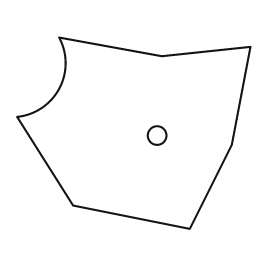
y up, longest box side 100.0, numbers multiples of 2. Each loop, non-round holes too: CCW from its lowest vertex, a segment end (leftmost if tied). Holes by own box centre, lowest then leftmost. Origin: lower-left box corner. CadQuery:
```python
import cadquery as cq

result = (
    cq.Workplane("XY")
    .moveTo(74.0, 0.0)
    .lineTo(92.0, 36.0)
    .lineTo(100.0, 78.0)
    .lineTo(62.0, 74.0)
    .lineTo(18.0, 82.0)
    .threePointArc((18.0, 60.0), (0.0, 48.0))
    .lineTo(24.0, 10.0)
    .close()
    .moveTo(60.0, 40.0)
    .circle(4.0)
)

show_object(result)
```